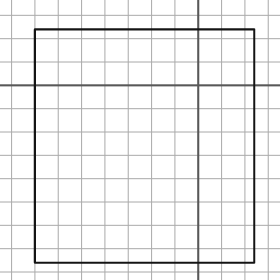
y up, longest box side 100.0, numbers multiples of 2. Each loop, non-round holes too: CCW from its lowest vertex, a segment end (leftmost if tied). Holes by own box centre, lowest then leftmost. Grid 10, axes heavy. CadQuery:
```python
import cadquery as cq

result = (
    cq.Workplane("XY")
    .moveTo(-70.0, -76.0)
    .lineTo(24.0, -76.0)
    .lineTo(24.0, 24.0)
    .lineTo(-70.0, 24.0)
    .close()
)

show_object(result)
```